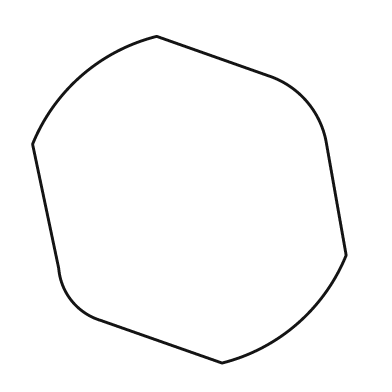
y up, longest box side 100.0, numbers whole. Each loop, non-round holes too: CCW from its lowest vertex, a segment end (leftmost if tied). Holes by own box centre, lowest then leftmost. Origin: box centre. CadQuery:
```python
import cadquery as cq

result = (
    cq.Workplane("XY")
    .moveTo(10.0, -50.0)
    .threePointArc((33.0, -38.0), (48.0, -17.0))
    .lineTo(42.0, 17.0)
    .threePointArc((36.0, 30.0), (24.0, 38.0))
    .lineTo(-10.0, 50.0)
    .threePointArc((-33.0, 38.0), (-48.0, 17.0))
    .lineTo(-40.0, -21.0)
    .threePointArc((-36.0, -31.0), (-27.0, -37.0))
    .close()
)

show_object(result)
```